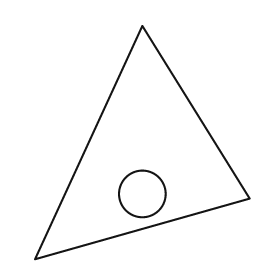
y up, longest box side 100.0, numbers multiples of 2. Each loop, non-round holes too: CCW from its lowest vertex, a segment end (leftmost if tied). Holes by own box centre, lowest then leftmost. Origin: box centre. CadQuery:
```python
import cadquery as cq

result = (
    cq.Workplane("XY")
    .moveTo(-46.0, -50.0)
    .lineTo(46.0, -24.0)
    .lineTo(0.0, 50.0)
    .close()
    .moveTo(0.0, -22.0)
    .circle(10.0)
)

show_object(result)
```